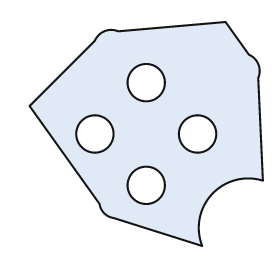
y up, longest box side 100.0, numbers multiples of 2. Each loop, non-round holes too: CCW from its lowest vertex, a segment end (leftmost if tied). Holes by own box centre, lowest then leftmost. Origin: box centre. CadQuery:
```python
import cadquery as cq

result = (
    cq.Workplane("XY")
    .moveTo(24.0, -48.0)
    .threePointArc((28.0, -26.0), (50.0, -20.0))
    .lineTo(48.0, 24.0)
    .threePointArc((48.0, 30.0), (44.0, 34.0))
    .lineTo(34.0, 48.0)
    .lineTo(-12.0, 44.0)
    .threePointArc((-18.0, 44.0), (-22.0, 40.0))
    .lineTo(-50.0, 12.0)
    .lineTo(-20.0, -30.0)
    .threePointArc((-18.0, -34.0), (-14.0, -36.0))
    .close()
    .moveTo(0.0, -22.0)
    .circle(8.0)
    .moveTo(-22.0, 0.0)
    .circle(8.0)
    .moveTo(22.0, 0.0)
    .circle(8.0)
    .moveTo(0.0, 22.0)
    .circle(8.0)
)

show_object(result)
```